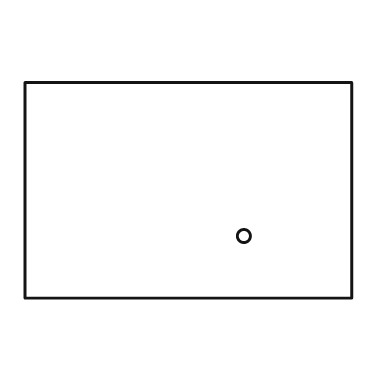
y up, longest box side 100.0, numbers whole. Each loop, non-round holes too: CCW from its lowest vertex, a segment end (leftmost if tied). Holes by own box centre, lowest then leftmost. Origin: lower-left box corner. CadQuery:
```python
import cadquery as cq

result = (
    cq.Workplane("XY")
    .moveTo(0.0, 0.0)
    .lineTo(100.0, 0.0)
    .lineTo(100.0, 66.0)
    .lineTo(0.0, 66.0)
    .close()
    .moveTo(67.0, 19.0)
    .circle(2.0)
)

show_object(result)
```